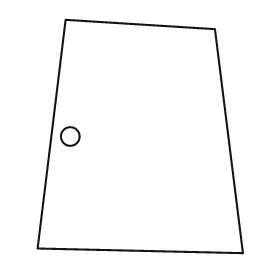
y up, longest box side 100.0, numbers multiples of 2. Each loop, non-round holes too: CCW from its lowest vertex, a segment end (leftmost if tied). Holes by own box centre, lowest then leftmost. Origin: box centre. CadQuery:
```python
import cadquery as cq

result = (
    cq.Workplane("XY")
    .moveTo(44.0, -50.0)
    .lineTo(32.0, 46.0)
    .lineTo(-32.0, 50.0)
    .lineTo(-44.0, -48.0)
    .close()
    .moveTo(-30.0, 0.0)
    .circle(4.0)
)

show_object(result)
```